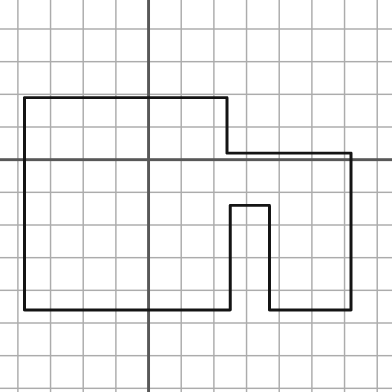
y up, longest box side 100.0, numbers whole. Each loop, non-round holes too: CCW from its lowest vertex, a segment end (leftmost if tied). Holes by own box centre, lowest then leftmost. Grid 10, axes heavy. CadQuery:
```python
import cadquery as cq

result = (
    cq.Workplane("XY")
    .moveTo(-38.0, -46.0)
    .lineTo(25.0, -46.0)
    .lineTo(25.0, -14.0)
    .lineTo(37.0, -14.0)
    .lineTo(37.0, -46.0)
    .lineTo(62.0, -46.0)
    .lineTo(62.0, 2.0)
    .lineTo(24.0, 2.0)
    .lineTo(24.0, 19.0)
    .lineTo(-38.0, 19.0)
    .close()
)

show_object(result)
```